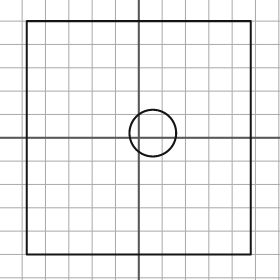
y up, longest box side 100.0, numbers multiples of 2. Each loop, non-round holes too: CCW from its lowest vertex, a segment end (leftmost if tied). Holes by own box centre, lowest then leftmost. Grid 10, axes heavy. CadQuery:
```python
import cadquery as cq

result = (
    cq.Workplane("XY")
    .moveTo(-48.0, -50.0)
    .lineTo(48.0, -50.0)
    .lineTo(48.0, 50.0)
    .lineTo(-48.0, 50.0)
    .close()
    .moveTo(6.0, 2.0)
    .circle(10.0)
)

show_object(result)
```